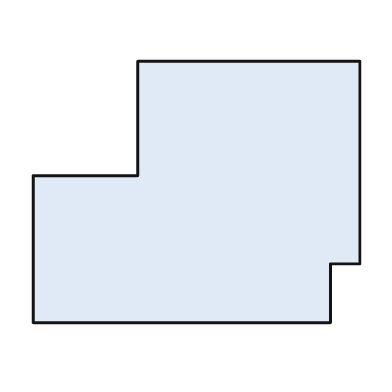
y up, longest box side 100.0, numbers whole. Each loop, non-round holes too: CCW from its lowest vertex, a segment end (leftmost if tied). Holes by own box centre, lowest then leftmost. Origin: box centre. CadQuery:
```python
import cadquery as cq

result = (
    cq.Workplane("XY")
    .moveTo(-50.0, -40.0)
    .lineTo(41.0, -40.0)
    .lineTo(41.0, -22.0)
    .lineTo(50.0, -22.0)
    .lineTo(50.0, 40.0)
    .lineTo(-18.0, 40.0)
    .lineTo(-18.0, 5.0)
    .lineTo(-50.0, 5.0)
    .close()
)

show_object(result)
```